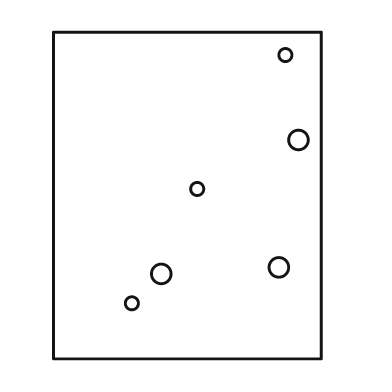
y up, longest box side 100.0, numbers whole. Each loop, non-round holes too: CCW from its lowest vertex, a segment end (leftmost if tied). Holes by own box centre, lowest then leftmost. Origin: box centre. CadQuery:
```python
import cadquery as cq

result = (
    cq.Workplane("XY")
    .moveTo(-41.0, -50.0)
    .lineTo(41.0, -50.0)
    .lineTo(41.0, 50.0)
    .lineTo(-41.0, 50.0)
    .close()
    .moveTo(-17.0, -33.0)
    .circle(2.0)
    .moveTo(-8.0, -24.0)
    .circle(3.0)
    .moveTo(28.0, -22.0)
    .circle(3.0)
    .moveTo(3.0, 2.0)
    .circle(2.0)
    .moveTo(34.0, 17.0)
    .circle(3.0)
    .moveTo(30.0, 43.0)
    .circle(2.0)
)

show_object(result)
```